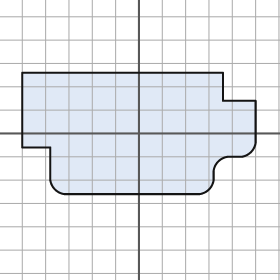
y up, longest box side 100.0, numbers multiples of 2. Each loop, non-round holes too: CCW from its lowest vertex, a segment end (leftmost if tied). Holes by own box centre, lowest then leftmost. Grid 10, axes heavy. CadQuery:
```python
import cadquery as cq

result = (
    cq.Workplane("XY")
    .moveTo(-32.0, -26.0)
    .lineTo(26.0, -26.0)
    .threePointArc((30.0, -24.0), (32.0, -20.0))
    .lineTo(32.0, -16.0)
    .threePointArc((34.0, -12.0), (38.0, -10.0))
    .lineTo(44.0, -10.0)
    .threePointArc((48.0, -8.0), (50.0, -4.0))
    .lineTo(50.0, 14.0)
    .lineTo(36.0, 14.0)
    .lineTo(36.0, 26.0)
    .lineTo(-50.0, 26.0)
    .lineTo(-50.0, -6.0)
    .lineTo(-38.0, -6.0)
    .lineTo(-38.0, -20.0)
    .threePointArc((-36.0, -24.0), (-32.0, -26.0))
    .close()
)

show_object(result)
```